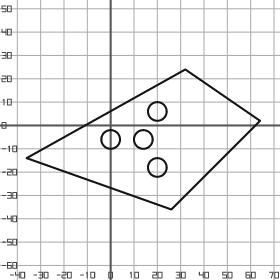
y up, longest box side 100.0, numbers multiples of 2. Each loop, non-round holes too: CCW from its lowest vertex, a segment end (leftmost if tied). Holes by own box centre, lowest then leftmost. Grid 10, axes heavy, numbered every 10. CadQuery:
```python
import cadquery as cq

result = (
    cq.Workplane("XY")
    .moveTo(26.0, -36.0)
    .lineTo(64.0, 2.0)
    .lineTo(32.0, 24.0)
    .lineTo(-36.0, -14.0)
    .close()
    .moveTo(20.0, -18.0)
    .circle(4.0)
    .moveTo(0.0, -6.0)
    .circle(4.0)
    .moveTo(14.0, -6.0)
    .circle(4.0)
    .moveTo(20.0, 6.0)
    .circle(4.0)
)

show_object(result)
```